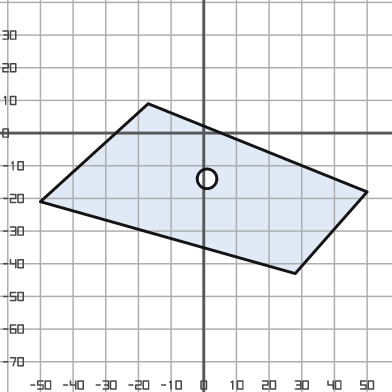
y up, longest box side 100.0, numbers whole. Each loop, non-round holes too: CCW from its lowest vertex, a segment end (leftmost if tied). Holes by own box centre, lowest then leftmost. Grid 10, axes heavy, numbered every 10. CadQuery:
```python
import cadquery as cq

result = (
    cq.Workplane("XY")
    .moveTo(28.0, -43.0)
    .lineTo(50.0, -18.0)
    .lineTo(-17.0, 9.0)
    .lineTo(-50.0, -21.0)
    .close()
    .moveTo(1.0, -14.0)
    .circle(3.0)
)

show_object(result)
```